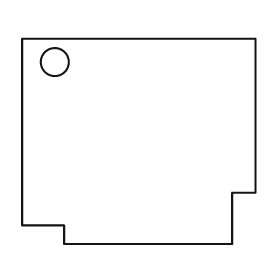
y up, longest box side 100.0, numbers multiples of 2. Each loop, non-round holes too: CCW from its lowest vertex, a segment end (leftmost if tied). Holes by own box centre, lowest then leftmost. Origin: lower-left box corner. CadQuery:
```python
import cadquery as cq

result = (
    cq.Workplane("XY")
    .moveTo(18.0, 0.0)
    .lineTo(90.0, 0.0)
    .lineTo(90.0, 22.0)
    .lineTo(100.0, 22.0)
    .lineTo(100.0, 88.0)
    .lineTo(0.0, 88.0)
    .lineTo(0.0, 8.0)
    .lineTo(18.0, 8.0)
    .close()
    .moveTo(14.0, 78.0)
    .circle(6.0)
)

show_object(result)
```